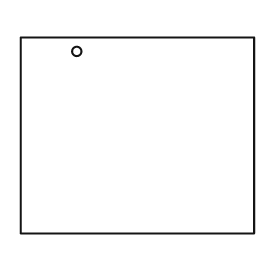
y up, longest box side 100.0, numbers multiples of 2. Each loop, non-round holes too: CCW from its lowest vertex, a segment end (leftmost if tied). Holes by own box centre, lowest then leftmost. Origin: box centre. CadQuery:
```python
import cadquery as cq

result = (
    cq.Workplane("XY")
    .moveTo(-50.0, -42.0)
    .lineTo(50.0, -42.0)
    .lineTo(50.0, 42.0)
    .lineTo(-50.0, 42.0)
    .close()
    .moveTo(-26.0, 36.0)
    .circle(2.0)
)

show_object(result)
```